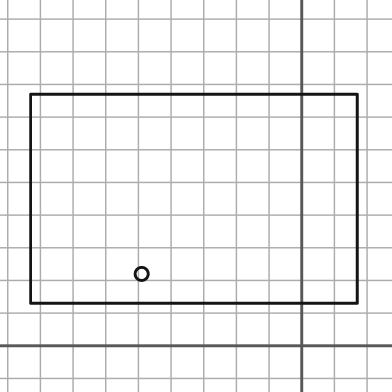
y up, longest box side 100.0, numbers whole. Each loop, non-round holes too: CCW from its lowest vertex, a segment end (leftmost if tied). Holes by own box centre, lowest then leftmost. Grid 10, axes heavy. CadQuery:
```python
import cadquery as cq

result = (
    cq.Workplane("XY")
    .moveTo(-83.0, 13.0)
    .lineTo(17.0, 13.0)
    .lineTo(17.0, 77.0)
    .lineTo(-83.0, 77.0)
    .close()
    .moveTo(-49.0, 22.0)
    .circle(2.0)
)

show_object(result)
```